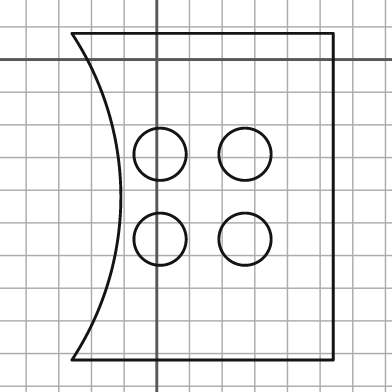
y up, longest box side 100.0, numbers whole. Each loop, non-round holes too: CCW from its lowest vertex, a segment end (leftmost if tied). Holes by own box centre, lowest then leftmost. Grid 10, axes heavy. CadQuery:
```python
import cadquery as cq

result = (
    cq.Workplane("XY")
    .moveTo(-26.0, -92.0)
    .lineTo(54.0, -92.0)
    .lineTo(54.0, 8.0)
    .lineTo(-26.0, 8.0)
    .threePointArc((-11.0, -42.0), (-26.0, -92.0))
    .close()
    .moveTo(1.0, -55.0)
    .circle(8.0)
    .moveTo(27.0, -55.0)
    .circle(8.0)
    .moveTo(1.0, -29.0)
    .circle(8.0)
    .moveTo(27.0, -29.0)
    .circle(8.0)
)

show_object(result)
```